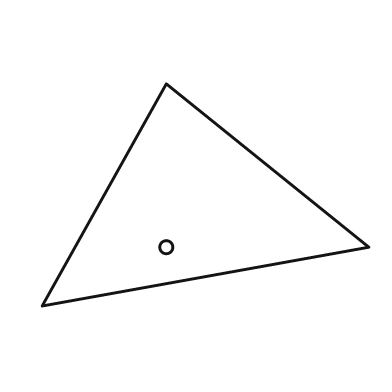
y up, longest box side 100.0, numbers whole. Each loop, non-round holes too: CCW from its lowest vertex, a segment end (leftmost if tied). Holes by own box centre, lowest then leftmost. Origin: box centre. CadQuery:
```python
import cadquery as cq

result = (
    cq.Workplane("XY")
    .moveTo(-50.0, -34.0)
    .lineTo(50.0, -16.0)
    .lineTo(-12.0, 34.0)
    .close()
    .moveTo(-12.0, -16.0)
    .circle(2.0)
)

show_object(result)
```